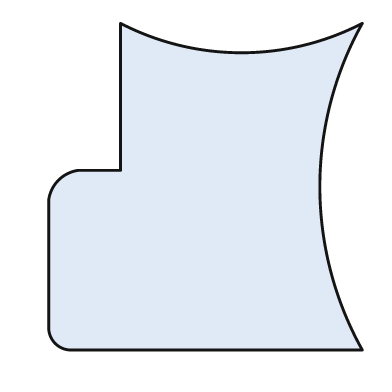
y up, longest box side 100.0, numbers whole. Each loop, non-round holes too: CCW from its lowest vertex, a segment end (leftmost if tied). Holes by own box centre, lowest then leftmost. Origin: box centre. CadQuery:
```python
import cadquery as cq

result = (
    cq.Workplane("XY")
    .moveTo(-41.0, -50.0)
    .lineTo(48.0, -50.0)
    .threePointArc((35.0, 0.0), (48.0, 50.0))
    .threePointArc((11.0, 41.0), (-26.0, 50.0))
    .lineTo(-26.0, 5.0)
    .lineTo(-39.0, 5.0)
    .threePointArc((-45.0, 2.0), (-48.0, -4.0))
    .lineTo(-48.0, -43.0)
    .threePointArc((-46.0, -48.0), (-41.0, -50.0))
    .close()
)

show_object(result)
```